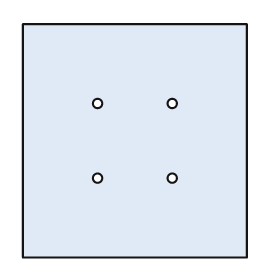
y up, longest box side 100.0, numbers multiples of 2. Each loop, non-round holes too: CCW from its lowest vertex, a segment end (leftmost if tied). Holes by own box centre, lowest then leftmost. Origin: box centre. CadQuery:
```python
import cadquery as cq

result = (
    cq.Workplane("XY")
    .moveTo(-48.0, -50.0)
    .lineTo(48.0, -50.0)
    .lineTo(48.0, 50.0)
    .lineTo(-48.0, 50.0)
    .close()
    .moveTo(-16.0, -16.0)
    .circle(2.0)
    .moveTo(16.0, -16.0)
    .circle(2.0)
    .moveTo(-16.0, 16.0)
    .circle(2.0)
    .moveTo(16.0, 16.0)
    .circle(2.0)
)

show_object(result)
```